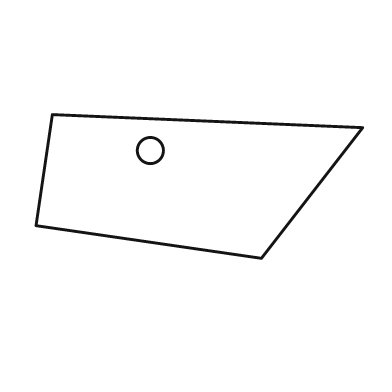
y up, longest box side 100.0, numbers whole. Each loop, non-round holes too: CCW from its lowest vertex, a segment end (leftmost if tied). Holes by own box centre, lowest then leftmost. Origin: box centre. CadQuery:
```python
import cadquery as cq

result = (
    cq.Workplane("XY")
    .moveTo(19.0, -22.0)
    .lineTo(50.0, 18.0)
    .lineTo(-45.0, 22.0)
    .lineTo(-50.0, -12.0)
    .close()
    .moveTo(-15.0, 11.0)
    .circle(4.0)
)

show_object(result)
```